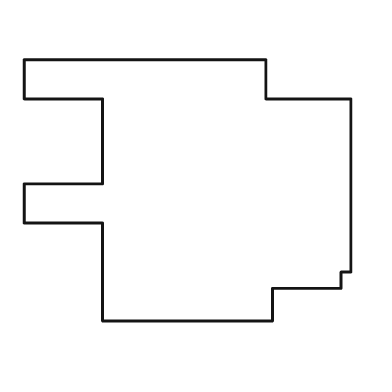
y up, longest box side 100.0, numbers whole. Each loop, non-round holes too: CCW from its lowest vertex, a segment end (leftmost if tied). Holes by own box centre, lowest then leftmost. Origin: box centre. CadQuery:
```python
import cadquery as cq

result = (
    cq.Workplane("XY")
    .moveTo(-26.0, -40.0)
    .lineTo(26.0, -40.0)
    .lineTo(26.0, -30.0)
    .lineTo(47.0, -30.0)
    .lineTo(47.0, -25.0)
    .lineTo(50.0, -25.0)
    .lineTo(50.0, 28.0)
    .lineTo(24.0, 28.0)
    .lineTo(24.0, 40.0)
    .lineTo(-50.0, 40.0)
    .lineTo(-50.0, 28.0)
    .lineTo(-26.0, 28.0)
    .lineTo(-26.0, 2.0)
    .lineTo(-50.0, 2.0)
    .lineTo(-50.0, -10.0)
    .lineTo(-26.0, -10.0)
    .close()
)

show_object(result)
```